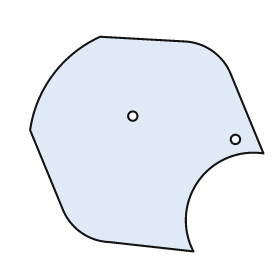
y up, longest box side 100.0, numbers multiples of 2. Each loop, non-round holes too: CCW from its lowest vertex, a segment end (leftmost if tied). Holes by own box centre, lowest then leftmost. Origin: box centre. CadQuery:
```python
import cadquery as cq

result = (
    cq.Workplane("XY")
    .moveTo(20.0, -46.0)
    .threePointArc((22.0, -16.0), (50.0, -4.0))
    .lineTo(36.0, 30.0)
    .threePointArc((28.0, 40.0), (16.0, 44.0))
    .lineTo(-20.0, 46.0)
    .threePointArc((-40.0, 30.0), (-50.0, 6.0))
    .lineTo(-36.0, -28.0)
    .threePointArc((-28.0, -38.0), (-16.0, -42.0))
    .close()
    .moveTo(38.0, 2.0)
    .circle(2.0)
    .moveTo(-6.0, 12.0)
    .circle(2.0)
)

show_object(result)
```